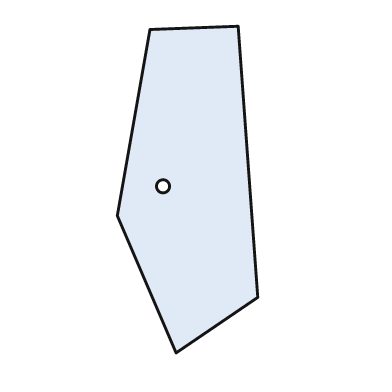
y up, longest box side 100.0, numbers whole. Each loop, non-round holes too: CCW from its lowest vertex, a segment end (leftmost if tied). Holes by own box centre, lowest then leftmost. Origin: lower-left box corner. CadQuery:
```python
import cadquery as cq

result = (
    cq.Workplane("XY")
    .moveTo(18.0, 0.0)
    .lineTo(43.0, 17.0)
    .lineTo(37.0, 100.0)
    .lineTo(10.0, 99.0)
    .lineTo(0.0, 42.0)
    .close()
    .moveTo(14.0, 51.0)
    .circle(2.0)
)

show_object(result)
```